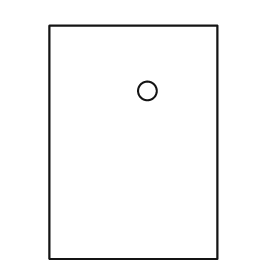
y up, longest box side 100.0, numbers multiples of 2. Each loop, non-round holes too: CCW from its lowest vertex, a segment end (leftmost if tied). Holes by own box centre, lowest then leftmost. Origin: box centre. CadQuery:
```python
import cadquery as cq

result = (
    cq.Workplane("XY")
    .moveTo(-36.0, -50.0)
    .lineTo(36.0, -50.0)
    .lineTo(36.0, 50.0)
    .lineTo(-36.0, 50.0)
    .close()
    .moveTo(6.0, 22.0)
    .circle(4.0)
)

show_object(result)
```